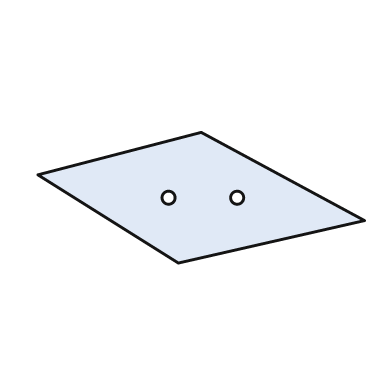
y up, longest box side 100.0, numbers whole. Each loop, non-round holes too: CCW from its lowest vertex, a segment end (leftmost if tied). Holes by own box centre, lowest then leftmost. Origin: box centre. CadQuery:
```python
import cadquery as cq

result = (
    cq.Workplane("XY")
    .moveTo(-7.0, -20.0)
    .lineTo(50.0, -7.0)
    .lineTo(0.0, 20.0)
    .lineTo(-50.0, 7.0)
    .close()
    .moveTo(-10.0, 0.0)
    .circle(2.0)
    .moveTo(11.0, 0.0)
    .circle(2.0)
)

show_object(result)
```